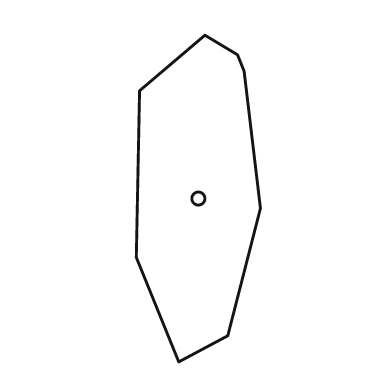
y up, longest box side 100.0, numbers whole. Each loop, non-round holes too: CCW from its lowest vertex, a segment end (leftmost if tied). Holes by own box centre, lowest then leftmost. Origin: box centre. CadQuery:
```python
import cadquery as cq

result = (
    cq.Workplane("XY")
    .moveTo(-6.0, -50.0)
    .lineTo(9.0, -42.0)
    .lineTo(19.0, -3.0)
    .lineTo(14.0, 39.0)
    .lineTo(12.0, 44.0)
    .lineTo(2.0, 50.0)
    .lineTo(-18.0, 33.0)
    .lineTo(-19.0, -18.0)
    .close()
    .moveTo(0.0, 0.0)
    .circle(2.0)
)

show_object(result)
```